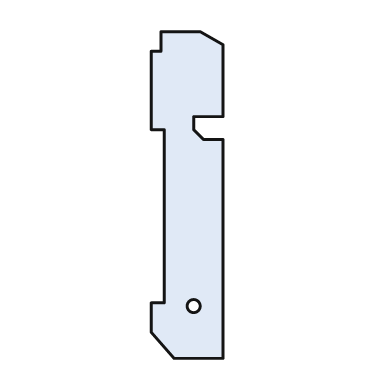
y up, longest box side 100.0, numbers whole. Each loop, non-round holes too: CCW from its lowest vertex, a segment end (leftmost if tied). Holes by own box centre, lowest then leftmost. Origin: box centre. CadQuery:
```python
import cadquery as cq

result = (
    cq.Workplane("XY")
    .moveTo(-4.0, -50.0)
    .lineTo(11.0, -50.0)
    .lineTo(11.0, 17.0)
    .lineTo(5.0, 17.0)
    .lineTo(2.0, 20.0)
    .lineTo(2.0, 24.0)
    .lineTo(11.0, 24.0)
    .lineTo(11.0, 46.0)
    .lineTo(4.0, 50.0)
    .lineTo(-8.0, 50.0)
    .lineTo(-8.0, 44.0)
    .lineTo(-11.0, 44.0)
    .lineTo(-11.0, 20.0)
    .lineTo(-7.0, 20.0)
    .lineTo(-7.0, -33.0)
    .lineTo(-11.0, -33.0)
    .lineTo(-11.0, -42.0)
    .close()
    .moveTo(2.0, -34.0)
    .circle(2.0)
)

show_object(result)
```